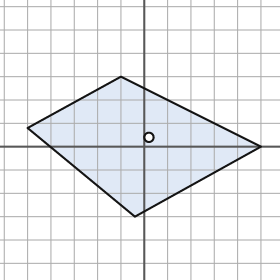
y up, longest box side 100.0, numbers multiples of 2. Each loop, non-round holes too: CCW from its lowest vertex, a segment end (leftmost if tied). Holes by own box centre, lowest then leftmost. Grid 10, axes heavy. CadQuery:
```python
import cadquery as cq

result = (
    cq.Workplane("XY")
    .moveTo(-4.0, -30.0)
    .lineTo(50.0, 0.0)
    .lineTo(-10.0, 30.0)
    .lineTo(-50.0, 8.0)
    .close()
    .moveTo(2.0, 4.0)
    .circle(2.0)
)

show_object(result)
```